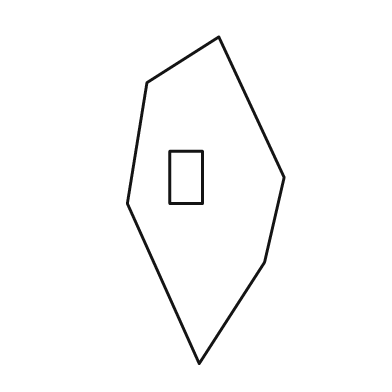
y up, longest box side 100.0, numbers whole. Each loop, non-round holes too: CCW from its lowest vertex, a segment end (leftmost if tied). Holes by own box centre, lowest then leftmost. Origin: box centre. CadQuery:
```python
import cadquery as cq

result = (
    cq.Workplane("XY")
    .moveTo(-2.0, -50.0)
    .lineTo(18.0, -19.0)
    .lineTo(24.0, 7.0)
    .lineTo(4.0, 50.0)
    .lineTo(-18.0, 36.0)
    .lineTo(-24.0, -1.0)
    .close()
    .moveTo(-11.0, -1.0)
    .lineTo(-1.0, -1.0)
    .lineTo(-1.0, 15.0)
    .lineTo(-11.0, 15.0)
    .close()
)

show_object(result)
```